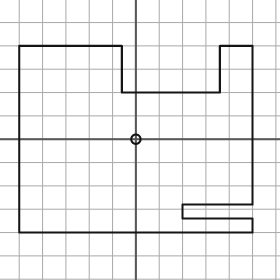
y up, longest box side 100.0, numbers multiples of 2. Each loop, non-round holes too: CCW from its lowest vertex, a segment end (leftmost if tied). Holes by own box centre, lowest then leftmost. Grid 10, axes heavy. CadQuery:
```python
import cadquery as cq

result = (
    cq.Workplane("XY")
    .moveTo(-50.0, -40.0)
    .lineTo(50.0, -40.0)
    .lineTo(50.0, -34.0)
    .lineTo(20.0, -34.0)
    .lineTo(20.0, -28.0)
    .lineTo(50.0, -28.0)
    .lineTo(50.0, 40.0)
    .lineTo(36.0, 40.0)
    .lineTo(36.0, 20.0)
    .lineTo(-6.0, 20.0)
    .lineTo(-6.0, 40.0)
    .lineTo(-50.0, 40.0)
    .close()
    .moveTo(0.0, 0.0)
    .circle(2.0)
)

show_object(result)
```